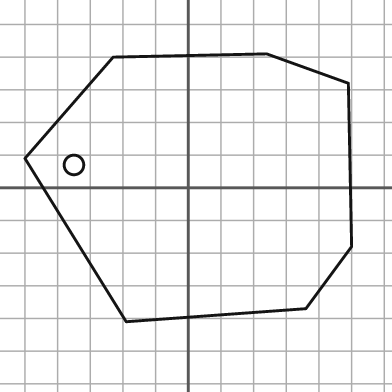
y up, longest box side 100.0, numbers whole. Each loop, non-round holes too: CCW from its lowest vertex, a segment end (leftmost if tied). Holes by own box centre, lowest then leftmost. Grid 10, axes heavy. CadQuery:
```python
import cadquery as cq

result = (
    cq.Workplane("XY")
    .moveTo(-19.0, -41.0)
    .lineTo(36.0, -37.0)
    .lineTo(50.0, -18.0)
    .lineTo(49.0, 32.0)
    .lineTo(24.0, 41.0)
    .lineTo(-23.0, 40.0)
    .lineTo(-50.0, 9.0)
    .close()
    .moveTo(-35.0, 7.0)
    .circle(3.0)
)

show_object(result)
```